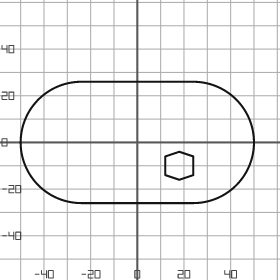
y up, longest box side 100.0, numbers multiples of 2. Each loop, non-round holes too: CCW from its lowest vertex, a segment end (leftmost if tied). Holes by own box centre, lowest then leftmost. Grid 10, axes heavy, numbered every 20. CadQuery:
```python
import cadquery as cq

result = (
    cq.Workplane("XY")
    .moveTo(-24.0, -26.0)
    .lineTo(24.0, -26.0)
    .threePointArc((50.0, 0.0), (24.0, 26.0))
    .lineTo(-24.0, 26.0)
    .threePointArc((-50.0, 0.0), (-24.0, -26.0))
    .close()
    .moveTo(18.0, -16.0)
    .lineTo(24.0, -14.0)
    .lineTo(24.0, -6.0)
    .lineTo(18.0, -4.0)
    .lineTo(12.0, -6.0)
    .lineTo(12.0, -14.0)
    .close()
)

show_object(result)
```